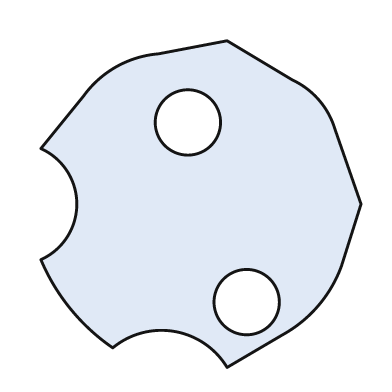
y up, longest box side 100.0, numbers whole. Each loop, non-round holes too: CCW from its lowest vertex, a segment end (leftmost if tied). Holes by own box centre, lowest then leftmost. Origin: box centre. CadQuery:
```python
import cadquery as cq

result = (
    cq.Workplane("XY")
    .moveTo(8.0, -50.0)
    .lineTo(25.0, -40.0)
    .threePointArc((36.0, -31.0), (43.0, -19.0))
    .lineTo(49.0, 0.0)
    .lineTo(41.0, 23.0)
    .threePointArc((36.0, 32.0), (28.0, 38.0))
    .lineTo(8.0, 50.0)
    .lineTo(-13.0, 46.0)
    .threePointArc((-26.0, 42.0), (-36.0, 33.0))
    .lineTo(-49.0, 17.0)
    .threePointArc((-38.0, 0.0), (-49.0, -17.0))
    .threePointArc((-40.0, -32.0), (-27.0, -44.0))
    .threePointArc((-8.0, -39.0), (8.0, -50.0))
    .close()
    .moveTo(14.0, -30.0)
    .circle(10.0)
    .moveTo(-4.0, 25.0)
    .circle(10.0)
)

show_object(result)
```